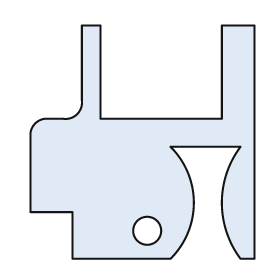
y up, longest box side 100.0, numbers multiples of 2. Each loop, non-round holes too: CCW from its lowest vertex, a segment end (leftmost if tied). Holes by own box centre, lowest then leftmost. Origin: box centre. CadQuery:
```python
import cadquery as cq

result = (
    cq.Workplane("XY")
    .moveTo(-30.0, -50.0)
    .lineTo(12.0, -50.0)
    .threePointArc((22.0, -26.0), (12.0, -2.0))
    .lineTo(42.0, -2.0)
    .threePointArc((34.0, -26.0), (42.0, -50.0))
    .lineTo(48.0, -50.0)
    .lineTo(48.0, 50.0)
    .lineTo(34.0, 50.0)
    .lineTo(34.0, 10.0)
    .lineTo(-18.0, 10.0)
    .lineTo(-18.0, 50.0)
    .lineTo(-26.0, 50.0)
    .lineTo(-26.0, 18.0)
    .threePointArc((-28.0, 12.0), (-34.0, 10.0))
    .lineTo(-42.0, 10.0)
    .threePointArc((-46.0, 8.0), (-48.0, 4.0))
    .lineTo(-48.0, -30.0)
    .lineTo(-30.0, -30.0)
    .close()
    .moveTo(2.0, -38.0)
    .circle(6.0)
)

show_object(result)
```